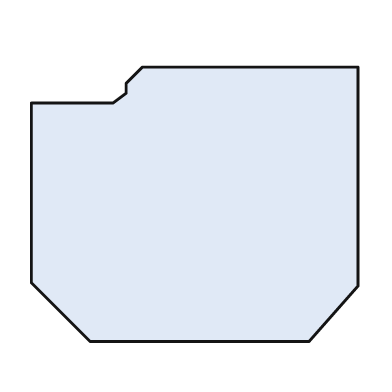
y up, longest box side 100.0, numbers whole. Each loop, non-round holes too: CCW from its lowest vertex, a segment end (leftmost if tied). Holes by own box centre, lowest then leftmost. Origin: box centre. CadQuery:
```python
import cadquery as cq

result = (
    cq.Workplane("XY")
    .moveTo(-32.0, -42.0)
    .lineTo(35.0, -42.0)
    .lineTo(50.0, -25.0)
    .lineTo(50.0, 42.0)
    .lineTo(-16.0, 42.0)
    .lineTo(-21.0, 37.0)
    .lineTo(-21.0, 34.0)
    .lineTo(-25.0, 31.0)
    .lineTo(-50.0, 31.0)
    .lineTo(-50.0, -24.0)
    .close()
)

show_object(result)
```